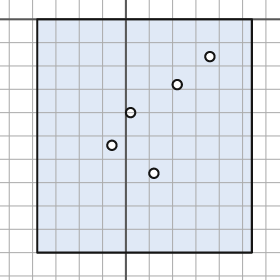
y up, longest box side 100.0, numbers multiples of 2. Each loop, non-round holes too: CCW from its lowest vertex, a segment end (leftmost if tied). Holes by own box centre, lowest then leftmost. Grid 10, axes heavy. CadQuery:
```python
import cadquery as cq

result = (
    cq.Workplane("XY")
    .moveTo(-38.0, -100.0)
    .lineTo(54.0, -100.0)
    .lineTo(54.0, 0.0)
    .lineTo(-38.0, 0.0)
    .close()
    .moveTo(12.0, -66.0)
    .circle(2.0)
    .moveTo(-6.0, -54.0)
    .circle(2.0)
    .moveTo(2.0, -40.0)
    .circle(2.0)
    .moveTo(22.0, -28.0)
    .circle(2.0)
    .moveTo(36.0, -16.0)
    .circle(2.0)
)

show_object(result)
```